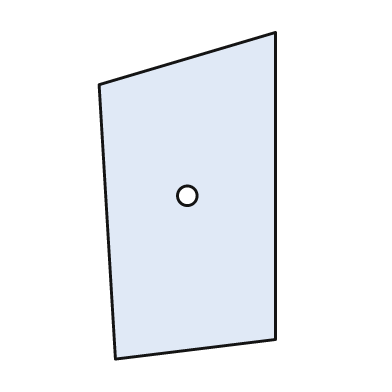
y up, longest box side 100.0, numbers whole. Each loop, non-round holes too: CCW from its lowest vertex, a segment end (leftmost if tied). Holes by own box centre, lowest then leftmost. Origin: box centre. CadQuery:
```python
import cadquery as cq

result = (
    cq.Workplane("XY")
    .moveTo(-22.0, -50.0)
    .lineTo(27.0, -44.0)
    .lineTo(27.0, 50.0)
    .lineTo(-27.0, 34.0)
    .close()
    .moveTo(0.0, 0.0)
    .circle(3.0)
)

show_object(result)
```